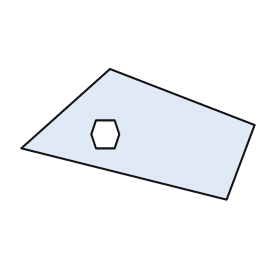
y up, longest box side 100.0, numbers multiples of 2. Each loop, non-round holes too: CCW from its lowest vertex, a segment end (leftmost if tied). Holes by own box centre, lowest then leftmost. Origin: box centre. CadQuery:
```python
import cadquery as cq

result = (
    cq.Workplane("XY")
    .moveTo(38.0, -28.0)
    .lineTo(50.0, 4.0)
    .lineTo(-12.0, 28.0)
    .lineTo(-50.0, -6.0)
    .close()
    .moveTo(-18.0, -6.0)
    .lineTo(-10.0, -6.0)
    .lineTo(-8.0, 0.0)
    .lineTo(-10.0, 6.0)
    .lineTo(-18.0, 6.0)
    .lineTo(-20.0, 0.0)
    .close()
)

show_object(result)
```